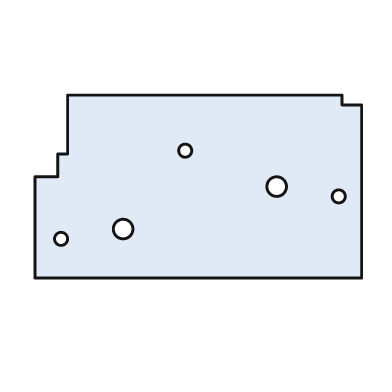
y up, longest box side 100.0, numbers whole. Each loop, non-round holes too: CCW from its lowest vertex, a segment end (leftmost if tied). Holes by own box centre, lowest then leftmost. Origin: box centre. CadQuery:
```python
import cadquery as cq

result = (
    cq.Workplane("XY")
    .moveTo(-50.0, -28.0)
    .lineTo(50.0, -28.0)
    .lineTo(50.0, 25.0)
    .lineTo(44.0, 25.0)
    .lineTo(44.0, 28.0)
    .lineTo(-40.0, 28.0)
    .lineTo(-40.0, 10.0)
    .lineTo(-43.0, 10.0)
    .lineTo(-43.0, 3.0)
    .lineTo(-50.0, 3.0)
    .close()
    .moveTo(-42.0, -16.0)
    .circle(2.0)
    .moveTo(-23.0, -13.0)
    .circle(3.0)
    .moveTo(43.0, -3.0)
    .circle(2.0)
    .moveTo(24.0, 0.0)
    .circle(3.0)
    .moveTo(-4.0, 11.0)
    .circle(2.0)
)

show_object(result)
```